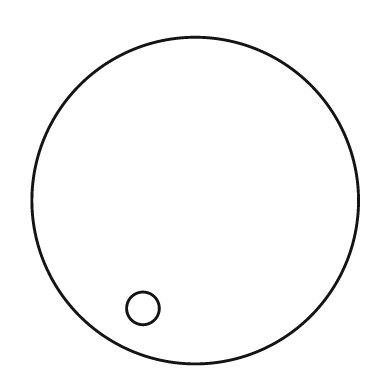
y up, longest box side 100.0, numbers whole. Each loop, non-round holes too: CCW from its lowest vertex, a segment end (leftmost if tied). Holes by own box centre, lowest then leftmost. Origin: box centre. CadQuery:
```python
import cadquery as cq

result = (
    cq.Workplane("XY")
    .moveTo(0.0, 0.0)
    .circle(50.0)
    .moveTo(-16.0, -33.0)
    .circle(5.0)
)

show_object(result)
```